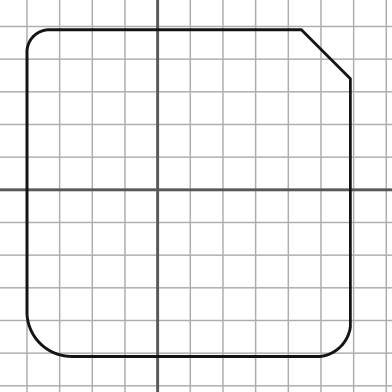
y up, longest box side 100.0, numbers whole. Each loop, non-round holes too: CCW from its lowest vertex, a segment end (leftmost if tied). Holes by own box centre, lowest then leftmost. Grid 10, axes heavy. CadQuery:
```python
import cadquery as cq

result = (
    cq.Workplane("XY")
    .moveTo(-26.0, -51.0)
    .lineTo(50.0, -51.0)
    .threePointArc((56.0, -48.0), (59.0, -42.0))
    .lineTo(59.0, 34.0)
    .lineTo(44.0, 49.0)
    .lineTo(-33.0, 49.0)
    .threePointArc((-38.0, 47.0), (-40.0, 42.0))
    .lineTo(-40.0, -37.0)
    .threePointArc((-36.0, -47.0), (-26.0, -51.0))
    .close()
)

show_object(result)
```